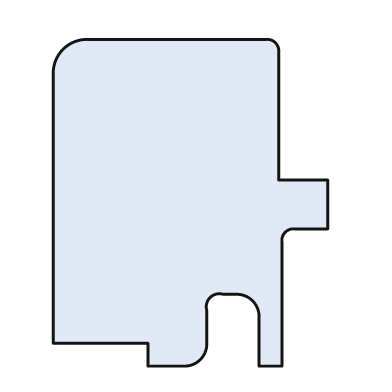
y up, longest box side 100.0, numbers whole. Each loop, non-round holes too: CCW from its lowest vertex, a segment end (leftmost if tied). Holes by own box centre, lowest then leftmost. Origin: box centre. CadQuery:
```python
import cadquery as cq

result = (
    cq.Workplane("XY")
    .moveTo(-13.0, -50.0)
    .lineTo(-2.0, -50.0)
    .threePointArc((3.0, -48.0), (5.0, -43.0))
    .lineTo(5.0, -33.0)
    .threePointArc((6.0, -29.0), (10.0, -28.0))
    .lineTo(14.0, -28.0)
    .threePointArc((19.0, -30.0), (21.0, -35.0))
    .lineTo(21.0, -50.0)
    .lineTo(28.0, -50.0)
    .lineTo(28.0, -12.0)
    .threePointArc((29.0, -9.0), (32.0, -8.0))
    .lineTo(42.0, -8.0)
    .lineTo(42.0, 7.0)
    .lineTo(27.0, 7.0)
    .lineTo(27.0, 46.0)
    .threePointArc((26.0, 49.0), (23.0, 50.0))
    .lineTo(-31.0, 50.0)
    .threePointArc((-39.0, 47.0), (-42.0, 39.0))
    .lineTo(-42.0, -43.0)
    .lineTo(-13.0, -43.0)
    .close()
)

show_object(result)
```